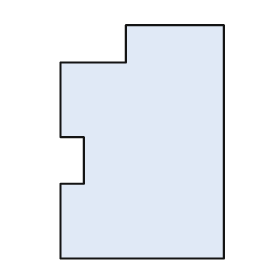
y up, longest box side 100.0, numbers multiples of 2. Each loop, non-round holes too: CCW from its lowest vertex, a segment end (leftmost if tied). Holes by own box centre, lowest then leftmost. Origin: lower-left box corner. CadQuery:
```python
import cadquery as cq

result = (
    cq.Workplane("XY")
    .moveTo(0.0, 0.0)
    .lineTo(70.0, 0.0)
    .lineTo(70.0, 100.0)
    .lineTo(28.0, 100.0)
    .lineTo(28.0, 84.0)
    .lineTo(0.0, 84.0)
    .lineTo(0.0, 52.0)
    .lineTo(10.0, 52.0)
    .lineTo(10.0, 32.0)
    .lineTo(0.0, 32.0)
    .close()
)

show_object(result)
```